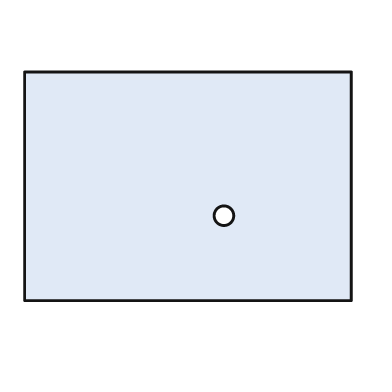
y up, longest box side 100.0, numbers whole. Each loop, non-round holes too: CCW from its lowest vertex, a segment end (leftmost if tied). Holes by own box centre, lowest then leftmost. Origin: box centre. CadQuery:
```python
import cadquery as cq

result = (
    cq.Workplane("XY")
    .moveTo(-50.0, -35.0)
    .lineTo(50.0, -35.0)
    .lineTo(50.0, 35.0)
    .lineTo(-50.0, 35.0)
    .close()
    .moveTo(11.0, -9.0)
    .circle(3.0)
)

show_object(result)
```